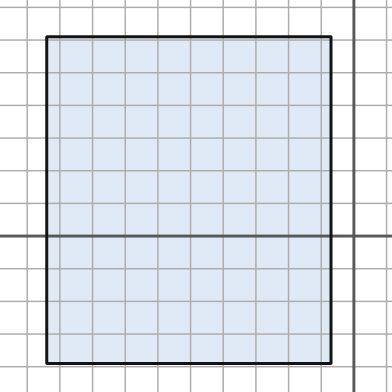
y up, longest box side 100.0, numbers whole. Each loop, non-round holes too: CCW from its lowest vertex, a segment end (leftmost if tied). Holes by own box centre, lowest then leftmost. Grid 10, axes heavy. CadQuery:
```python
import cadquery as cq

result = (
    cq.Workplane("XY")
    .moveTo(-94.0, -39.0)
    .lineTo(-7.0, -39.0)
    .lineTo(-7.0, 61.0)
    .lineTo(-94.0, 61.0)
    .close()
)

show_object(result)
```